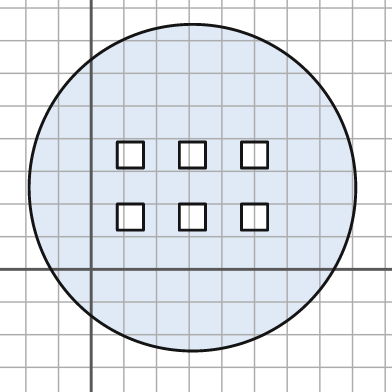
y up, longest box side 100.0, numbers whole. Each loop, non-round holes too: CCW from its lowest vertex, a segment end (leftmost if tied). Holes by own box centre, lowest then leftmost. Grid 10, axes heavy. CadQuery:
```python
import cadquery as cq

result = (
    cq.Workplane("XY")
    .moveTo(31.0, 25.0)
    .circle(50.0)
    .moveTo(8.0, 12.0)
    .lineTo(16.0, 12.0)
    .lineTo(16.0, 20.0)
    .lineTo(8.0, 20.0)
    .close()
    .moveTo(27.0, 12.0)
    .lineTo(35.0, 12.0)
    .lineTo(35.0, 20.0)
    .lineTo(27.0, 20.0)
    .close()
    .moveTo(46.0, 12.0)
    .lineTo(54.0, 12.0)
    .lineTo(54.0, 20.0)
    .lineTo(46.0, 20.0)
    .close()
    .moveTo(8.0, 31.0)
    .lineTo(16.0, 31.0)
    .lineTo(16.0, 39.0)
    .lineTo(8.0, 39.0)
    .close()
    .moveTo(27.0, 31.0)
    .lineTo(35.0, 31.0)
    .lineTo(35.0, 39.0)
    .lineTo(27.0, 39.0)
    .close()
    .moveTo(46.0, 31.0)
    .lineTo(54.0, 31.0)
    .lineTo(54.0, 39.0)
    .lineTo(46.0, 39.0)
    .close()
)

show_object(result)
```